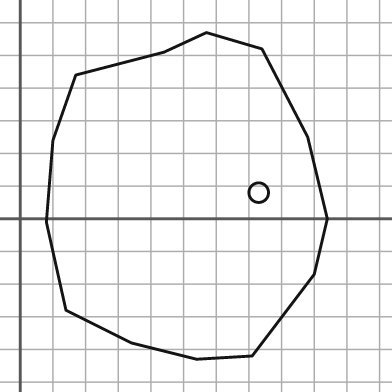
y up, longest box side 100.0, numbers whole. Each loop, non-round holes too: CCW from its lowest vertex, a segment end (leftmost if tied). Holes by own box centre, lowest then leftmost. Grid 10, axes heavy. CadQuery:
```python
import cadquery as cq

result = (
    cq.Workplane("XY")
    .moveTo(54.0, -43.0)
    .lineTo(71.0, -42.0)
    .lineTo(90.0, -17.0)
    .lineTo(94.0, 0.0)
    .lineTo(88.0, 25.0)
    .lineTo(74.0, 52.0)
    .lineTo(57.0, 57.0)
    .lineTo(44.0, 51.0)
    .lineTo(17.0, 44.0)
    .lineTo(10.0, 24.0)
    .lineTo(8.0, -1.0)
    .lineTo(14.0, -28.0)
    .lineTo(34.0, -38.0)
    .close()
    .moveTo(73.0, 8.0)
    .circle(3.0)
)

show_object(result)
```